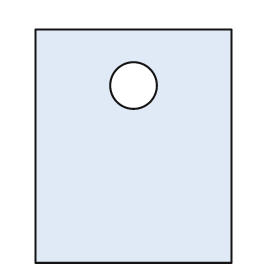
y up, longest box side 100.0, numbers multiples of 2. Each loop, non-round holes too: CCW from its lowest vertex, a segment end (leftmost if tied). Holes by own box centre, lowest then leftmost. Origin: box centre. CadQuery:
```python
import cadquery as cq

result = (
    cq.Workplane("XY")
    .moveTo(-42.0, -50.0)
    .lineTo(42.0, -50.0)
    .lineTo(42.0, 50.0)
    .lineTo(-42.0, 50.0)
    .close()
    .moveTo(0.0, 26.0)
    .circle(10.0)
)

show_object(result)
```